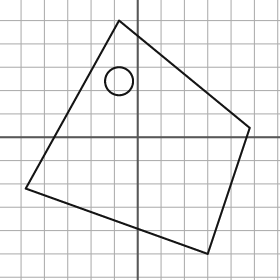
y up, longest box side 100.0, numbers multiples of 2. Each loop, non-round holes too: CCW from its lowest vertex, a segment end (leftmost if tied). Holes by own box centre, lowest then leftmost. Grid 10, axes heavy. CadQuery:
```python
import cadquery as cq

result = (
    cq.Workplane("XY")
    .moveTo(30.0, -50.0)
    .lineTo(48.0, 4.0)
    .lineTo(-8.0, 50.0)
    .lineTo(-48.0, -22.0)
    .close()
    .moveTo(-8.0, 24.0)
    .circle(6.0)
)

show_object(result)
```